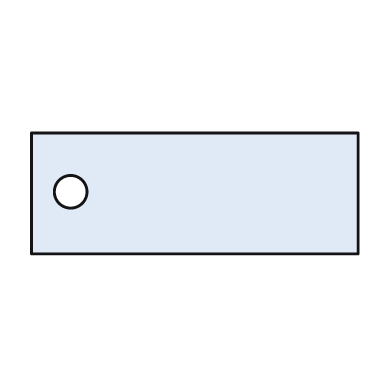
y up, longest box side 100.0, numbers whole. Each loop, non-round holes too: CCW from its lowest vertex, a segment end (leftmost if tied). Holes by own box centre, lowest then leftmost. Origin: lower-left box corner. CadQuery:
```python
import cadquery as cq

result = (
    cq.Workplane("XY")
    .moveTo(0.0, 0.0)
    .lineTo(100.0, 0.0)
    .lineTo(100.0, 37.0)
    .lineTo(0.0, 37.0)
    .close()
    .moveTo(12.0, 19.0)
    .circle(5.0)
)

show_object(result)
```